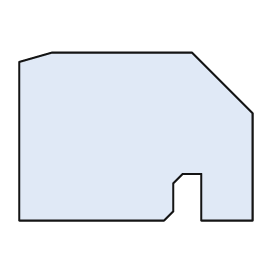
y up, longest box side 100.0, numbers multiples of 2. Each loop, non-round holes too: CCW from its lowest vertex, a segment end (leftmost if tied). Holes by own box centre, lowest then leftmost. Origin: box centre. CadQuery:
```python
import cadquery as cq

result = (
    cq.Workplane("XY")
    .moveTo(-50.0, -36.0)
    .lineTo(12.0, -36.0)
    .lineTo(16.0, -32.0)
    .lineTo(16.0, -20.0)
    .lineTo(20.0, -16.0)
    .lineTo(28.0, -16.0)
    .lineTo(28.0, -36.0)
    .lineTo(50.0, -36.0)
    .lineTo(50.0, 10.0)
    .lineTo(24.0, 36.0)
    .lineTo(-36.0, 36.0)
    .lineTo(-50.0, 32.0)
    .close()
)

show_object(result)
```